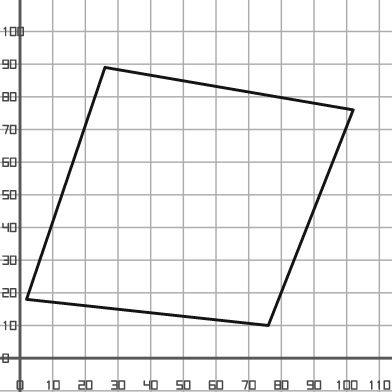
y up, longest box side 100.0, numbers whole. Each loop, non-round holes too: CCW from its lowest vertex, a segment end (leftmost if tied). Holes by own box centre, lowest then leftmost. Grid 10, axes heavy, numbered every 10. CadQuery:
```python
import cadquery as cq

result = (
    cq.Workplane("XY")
    .moveTo(76.0, 10.0)
    .lineTo(102.0, 76.0)
    .lineTo(26.0, 89.0)
    .lineTo(2.0, 18.0)
    .close()
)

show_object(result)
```